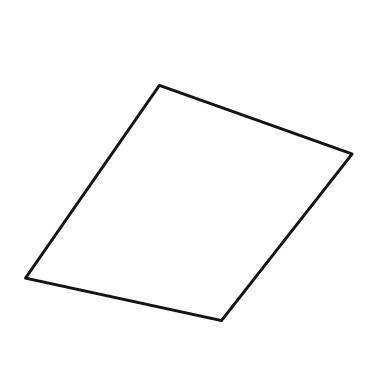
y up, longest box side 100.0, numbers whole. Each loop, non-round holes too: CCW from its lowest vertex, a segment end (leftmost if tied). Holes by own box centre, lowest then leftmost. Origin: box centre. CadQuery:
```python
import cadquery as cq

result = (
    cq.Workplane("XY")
    .moveTo(10.0, -36.0)
    .lineTo(50.0, 15.0)
    .lineTo(-9.0, 36.0)
    .lineTo(-50.0, -23.0)
    .close()
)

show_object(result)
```